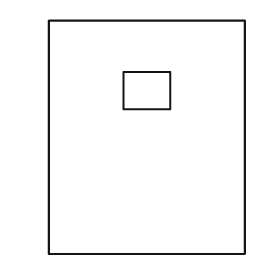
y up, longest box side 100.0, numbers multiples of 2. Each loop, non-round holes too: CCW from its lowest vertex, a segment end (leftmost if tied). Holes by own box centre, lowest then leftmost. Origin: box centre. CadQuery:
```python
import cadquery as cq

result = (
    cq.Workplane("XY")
    .moveTo(-42.0, -50.0)
    .lineTo(42.0, -50.0)
    .lineTo(42.0, 50.0)
    .lineTo(-42.0, 50.0)
    .close()
    .moveTo(-10.0, 12.0)
    .lineTo(10.0, 12.0)
    .lineTo(10.0, 28.0)
    .lineTo(-10.0, 28.0)
    .close()
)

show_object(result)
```